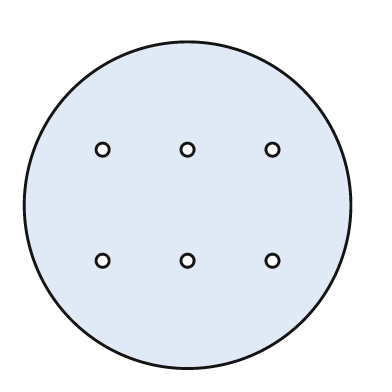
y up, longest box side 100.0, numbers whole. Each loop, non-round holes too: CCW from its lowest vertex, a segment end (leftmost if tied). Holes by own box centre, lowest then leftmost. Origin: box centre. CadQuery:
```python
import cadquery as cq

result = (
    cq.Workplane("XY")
    .moveTo(0.0, 0.0)
    .circle(50.0)
    .moveTo(-26.0, -17.0)
    .circle(2.0)
    .moveTo(0.0, -17.0)
    .circle(2.0)
    .moveTo(26.0, -17.0)
    .circle(2.0)
    .moveTo(-26.0, 17.0)
    .circle(2.0)
    .moveTo(0.0, 17.0)
    .circle(2.0)
    .moveTo(26.0, 17.0)
    .circle(2.0)
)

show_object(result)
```